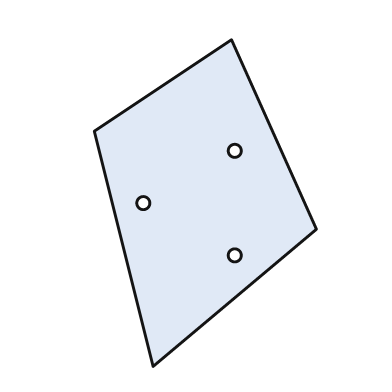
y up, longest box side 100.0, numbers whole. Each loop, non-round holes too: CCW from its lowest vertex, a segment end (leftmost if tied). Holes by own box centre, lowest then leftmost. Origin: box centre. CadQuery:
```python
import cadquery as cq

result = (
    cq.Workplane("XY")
    .moveTo(-16.0, -50.0)
    .lineTo(34.0, -8.0)
    .lineTo(8.0, 50.0)
    .lineTo(-34.0, 22.0)
    .close()
    .moveTo(9.0, -16.0)
    .circle(2.0)
    .moveTo(-19.0, 0.0)
    .circle(2.0)
    .moveTo(9.0, 16.0)
    .circle(2.0)
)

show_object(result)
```